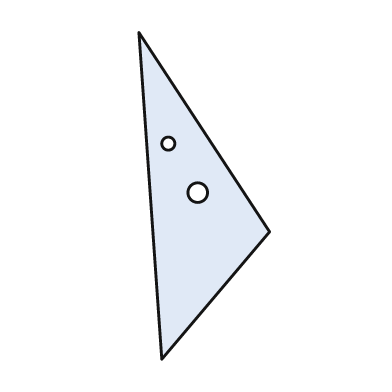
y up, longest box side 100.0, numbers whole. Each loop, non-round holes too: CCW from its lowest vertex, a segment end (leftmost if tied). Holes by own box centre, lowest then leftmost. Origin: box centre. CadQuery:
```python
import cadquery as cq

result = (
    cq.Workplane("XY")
    .moveTo(-13.0, -50.0)
    .lineTo(20.0, -11.0)
    .lineTo(-20.0, 50.0)
    .close()
    .moveTo(-2.0, 1.0)
    .circle(3.0)
    .moveTo(-11.0, 16.0)
    .circle(2.0)
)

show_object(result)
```